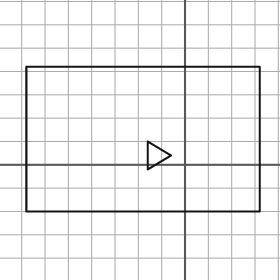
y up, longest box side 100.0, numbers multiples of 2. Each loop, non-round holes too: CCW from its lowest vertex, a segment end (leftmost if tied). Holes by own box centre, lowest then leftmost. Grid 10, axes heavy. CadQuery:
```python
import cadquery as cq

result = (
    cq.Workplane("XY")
    .moveTo(-68.0, -20.0)
    .lineTo(32.0, -20.0)
    .lineTo(32.0, 42.0)
    .lineTo(-68.0, 42.0)
    .close()
    .moveTo(-16.0, -2.0)
    .lineTo(-6.0, 4.0)
    .lineTo(-16.0, 10.0)
    .close()
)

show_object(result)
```